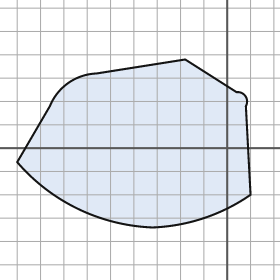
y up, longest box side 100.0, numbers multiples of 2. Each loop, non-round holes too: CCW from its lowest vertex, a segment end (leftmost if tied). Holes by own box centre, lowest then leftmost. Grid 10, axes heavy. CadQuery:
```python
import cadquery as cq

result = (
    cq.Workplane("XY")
    .moveTo(-32.0, -34.0)
    .threePointArc((-10.0, -30.0), (10.0, -20.0))
    .lineTo(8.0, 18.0)
    .threePointArc((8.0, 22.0), (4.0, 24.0))
    .lineTo(-18.0, 38.0)
    .lineTo(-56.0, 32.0)
    .threePointArc((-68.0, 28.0), (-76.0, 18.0))
    .lineTo(-90.0, -6.0)
    .threePointArc((-64.0, -26.0), (-32.0, -34.0))
    .close()
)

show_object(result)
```